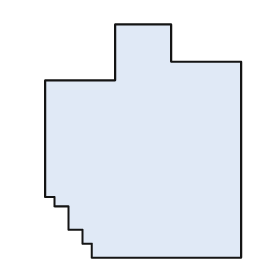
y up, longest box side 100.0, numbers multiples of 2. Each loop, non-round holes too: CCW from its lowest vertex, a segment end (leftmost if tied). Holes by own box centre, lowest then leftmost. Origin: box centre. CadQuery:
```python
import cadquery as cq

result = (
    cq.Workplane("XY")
    .moveTo(-22.0, -50.0)
    .lineTo(42.0, -50.0)
    .lineTo(42.0, 34.0)
    .lineTo(12.0, 34.0)
    .lineTo(12.0, 50.0)
    .lineTo(-12.0, 50.0)
    .lineTo(-12.0, 26.0)
    .lineTo(-42.0, 26.0)
    .lineTo(-42.0, -24.0)
    .lineTo(-38.0, -24.0)
    .lineTo(-38.0, -28.0)
    .lineTo(-32.0, -28.0)
    .lineTo(-32.0, -38.0)
    .lineTo(-26.0, -38.0)
    .lineTo(-26.0, -44.0)
    .lineTo(-22.0, -44.0)
    .close()
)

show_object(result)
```